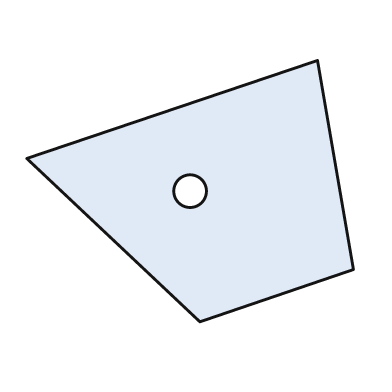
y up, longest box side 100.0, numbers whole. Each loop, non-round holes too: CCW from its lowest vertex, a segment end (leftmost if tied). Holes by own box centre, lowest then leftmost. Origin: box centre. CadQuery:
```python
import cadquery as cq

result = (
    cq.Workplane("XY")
    .moveTo(3.0, -40.0)
    .lineTo(50.0, -24.0)
    .lineTo(39.0, 40.0)
    .lineTo(-50.0, 10.0)
    .close()
    .moveTo(0.0, 0.0)
    .circle(5.0)
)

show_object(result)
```